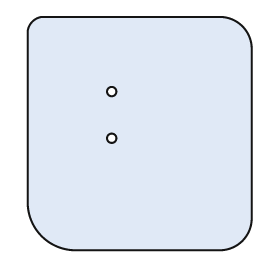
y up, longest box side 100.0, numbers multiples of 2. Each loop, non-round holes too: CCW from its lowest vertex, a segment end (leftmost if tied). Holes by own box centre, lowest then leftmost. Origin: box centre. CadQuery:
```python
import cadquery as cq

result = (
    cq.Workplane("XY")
    .moveTo(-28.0, -50.0)
    .lineTo(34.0, -50.0)
    .threePointArc((44.0, -46.0), (48.0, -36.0))
    .lineTo(48.0, 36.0)
    .threePointArc((44.0, 46.0), (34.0, 50.0))
    .lineTo(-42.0, 50.0)
    .threePointArc((-46.0, 48.0), (-48.0, 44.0))
    .lineTo(-48.0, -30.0)
    .threePointArc((-42.0, -44.0), (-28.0, -50.0))
    .close()
    .moveTo(-12.0, -2.0)
    .circle(2.0)
    .moveTo(-12.0, 18.0)
    .circle(2.0)
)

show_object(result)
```